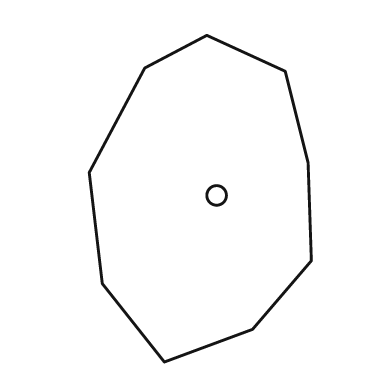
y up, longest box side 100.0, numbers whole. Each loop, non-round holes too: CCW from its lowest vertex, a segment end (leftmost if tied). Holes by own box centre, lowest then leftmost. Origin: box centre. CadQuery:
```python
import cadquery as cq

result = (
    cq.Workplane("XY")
    .moveTo(-11.0, -50.0)
    .lineTo(16.0, -40.0)
    .lineTo(34.0, -19.0)
    .lineTo(33.0, 11.0)
    .lineTo(26.0, 39.0)
    .lineTo(2.0, 50.0)
    .lineTo(-17.0, 40.0)
    .lineTo(-34.0, 8.0)
    .lineTo(-30.0, -26.0)
    .close()
    .moveTo(5.0, 1.0)
    .circle(3.0)
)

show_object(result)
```